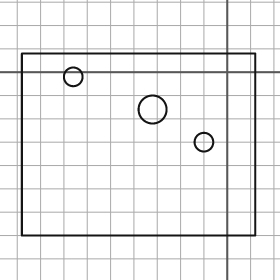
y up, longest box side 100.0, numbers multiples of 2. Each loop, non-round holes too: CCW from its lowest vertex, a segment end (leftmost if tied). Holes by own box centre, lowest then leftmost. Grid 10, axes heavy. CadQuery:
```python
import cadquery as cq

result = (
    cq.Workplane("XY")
    .moveTo(-88.0, -70.0)
    .lineTo(12.0, -70.0)
    .lineTo(12.0, 8.0)
    .lineTo(-88.0, 8.0)
    .close()
    .moveTo(-10.0, -30.0)
    .circle(4.0)
    .moveTo(-32.0, -16.0)
    .circle(6.0)
    .moveTo(-66.0, -2.0)
    .circle(4.0)
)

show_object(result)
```